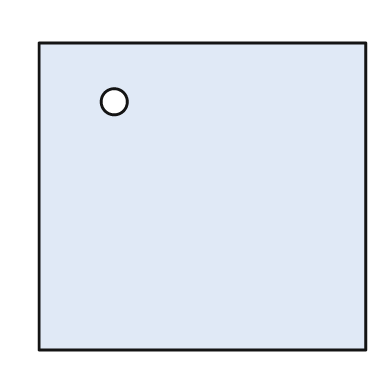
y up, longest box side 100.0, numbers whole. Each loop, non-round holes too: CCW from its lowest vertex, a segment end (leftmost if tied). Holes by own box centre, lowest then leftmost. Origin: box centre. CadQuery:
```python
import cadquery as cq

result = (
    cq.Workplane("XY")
    .moveTo(-50.0, -47.0)
    .lineTo(50.0, -47.0)
    .lineTo(50.0, 47.0)
    .lineTo(-50.0, 47.0)
    .close()
    .moveTo(-27.0, 29.0)
    .circle(4.0)
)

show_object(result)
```